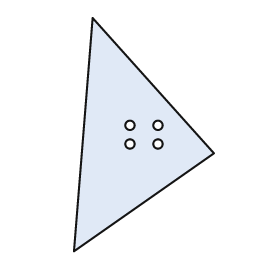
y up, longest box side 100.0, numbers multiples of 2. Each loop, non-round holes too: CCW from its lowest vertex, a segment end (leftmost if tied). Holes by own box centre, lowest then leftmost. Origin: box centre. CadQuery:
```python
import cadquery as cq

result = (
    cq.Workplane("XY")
    .moveTo(-30.0, -50.0)
    .lineTo(30.0, -8.0)
    .lineTo(-22.0, 50.0)
    .close()
    .moveTo(-6.0, -4.0)
    .circle(2.0)
    .moveTo(6.0, -4.0)
    .circle(2.0)
    .moveTo(-6.0, 4.0)
    .circle(2.0)
    .moveTo(6.0, 4.0)
    .circle(2.0)
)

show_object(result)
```